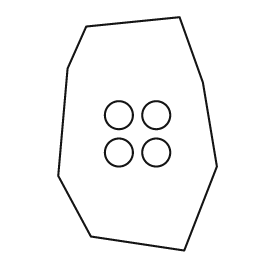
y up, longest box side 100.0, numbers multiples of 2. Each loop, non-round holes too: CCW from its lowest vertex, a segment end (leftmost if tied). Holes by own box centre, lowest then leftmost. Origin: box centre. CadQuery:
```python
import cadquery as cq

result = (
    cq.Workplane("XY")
    .moveTo(20.0, -50.0)
    .lineTo(34.0, -14.0)
    .lineTo(28.0, 22.0)
    .lineTo(18.0, 50.0)
    .lineTo(-22.0, 46.0)
    .lineTo(-30.0, 28.0)
    .lineTo(-34.0, -18.0)
    .lineTo(-20.0, -44.0)
    .close()
    .moveTo(-8.0, -8.0)
    .circle(6.0)
    .moveTo(8.0, -8.0)
    .circle(6.0)
    .moveTo(-8.0, 8.0)
    .circle(6.0)
    .moveTo(8.0, 8.0)
    .circle(6.0)
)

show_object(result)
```